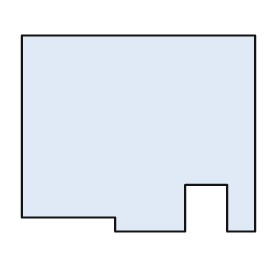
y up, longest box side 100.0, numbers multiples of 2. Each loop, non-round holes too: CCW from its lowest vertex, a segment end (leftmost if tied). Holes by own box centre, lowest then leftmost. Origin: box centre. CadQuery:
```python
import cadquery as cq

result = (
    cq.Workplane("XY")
    .moveTo(-10.0, -42.0)
    .lineTo(20.0, -42.0)
    .lineTo(20.0, -22.0)
    .lineTo(38.0, -22.0)
    .lineTo(38.0, -42.0)
    .lineTo(50.0, -42.0)
    .lineTo(50.0, 42.0)
    .lineTo(-50.0, 42.0)
    .lineTo(-50.0, -36.0)
    .lineTo(-10.0, -36.0)
    .close()
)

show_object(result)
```